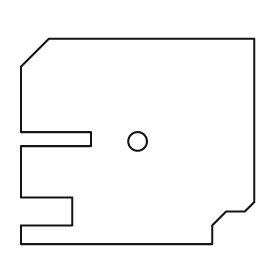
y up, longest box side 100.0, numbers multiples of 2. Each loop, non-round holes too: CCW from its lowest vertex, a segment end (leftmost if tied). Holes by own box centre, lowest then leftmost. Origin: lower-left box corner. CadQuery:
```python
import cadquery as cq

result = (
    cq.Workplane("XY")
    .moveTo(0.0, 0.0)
    .lineTo(82.0, 0.0)
    .lineTo(82.0, 8.0)
    .lineTo(88.0, 14.0)
    .lineTo(96.0, 14.0)
    .lineTo(100.0, 18.0)
    .lineTo(100.0, 88.0)
    .lineTo(12.0, 88.0)
    .lineTo(0.0, 76.0)
    .lineTo(0.0, 48.0)
    .lineTo(30.0, 48.0)
    .lineTo(30.0, 42.0)
    .lineTo(0.0, 42.0)
    .lineTo(0.0, 20.0)
    .lineTo(22.0, 20.0)
    .lineTo(22.0, 8.0)
    .lineTo(0.0, 8.0)
    .close()
    .moveTo(50.0, 44.0)
    .circle(4.0)
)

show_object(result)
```